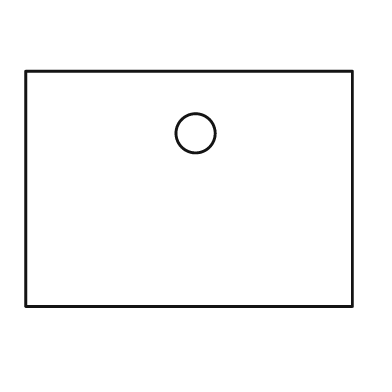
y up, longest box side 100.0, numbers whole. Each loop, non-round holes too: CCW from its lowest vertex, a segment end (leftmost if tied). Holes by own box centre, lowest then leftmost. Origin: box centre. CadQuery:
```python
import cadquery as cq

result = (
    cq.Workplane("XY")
    .moveTo(-50.0, -36.0)
    .lineTo(50.0, -36.0)
    .lineTo(50.0, 36.0)
    .lineTo(-50.0, 36.0)
    .close()
    .moveTo(2.0, 17.0)
    .circle(6.0)
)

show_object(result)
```